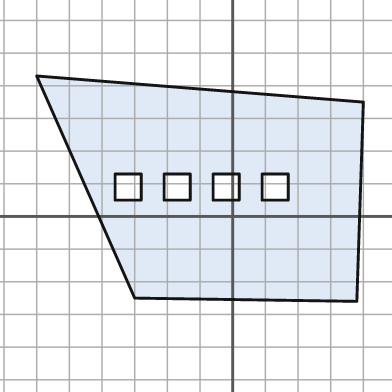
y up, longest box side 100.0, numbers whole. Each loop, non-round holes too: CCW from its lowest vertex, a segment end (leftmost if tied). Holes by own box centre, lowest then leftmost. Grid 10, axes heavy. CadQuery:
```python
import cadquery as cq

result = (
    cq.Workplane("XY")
    .moveTo(38.0, -26.0)
    .lineTo(40.0, 35.0)
    .lineTo(-60.0, 43.0)
    .lineTo(-30.0, -25.0)
    .close()
    .moveTo(-36.0, 5.0)
    .lineTo(-28.0, 5.0)
    .lineTo(-28.0, 13.0)
    .lineTo(-36.0, 13.0)
    .close()
    .moveTo(-21.0, 5.0)
    .lineTo(-13.0, 5.0)
    .lineTo(-13.0, 13.0)
    .lineTo(-21.0, 13.0)
    .close()
    .moveTo(-6.0, 5.0)
    .lineTo(2.0, 5.0)
    .lineTo(2.0, 13.0)
    .lineTo(-6.0, 13.0)
    .close()
    .moveTo(9.0, 5.0)
    .lineTo(17.0, 5.0)
    .lineTo(17.0, 13.0)
    .lineTo(9.0, 13.0)
    .close()
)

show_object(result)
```